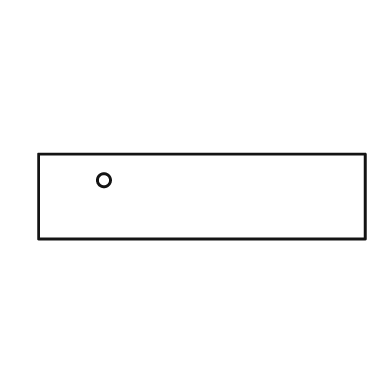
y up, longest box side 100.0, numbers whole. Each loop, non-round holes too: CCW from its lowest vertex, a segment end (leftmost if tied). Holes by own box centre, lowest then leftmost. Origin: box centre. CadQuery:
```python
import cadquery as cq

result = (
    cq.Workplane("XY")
    .moveTo(-50.0, -13.0)
    .lineTo(50.0, -13.0)
    .lineTo(50.0, 13.0)
    .lineTo(-50.0, 13.0)
    .close()
    .moveTo(-30.0, 5.0)
    .circle(2.0)
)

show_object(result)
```